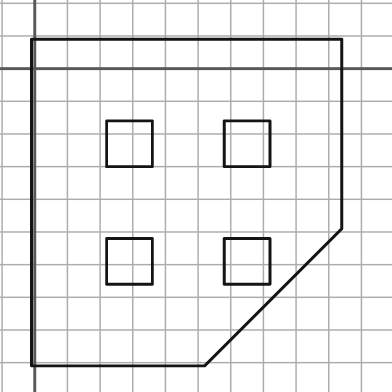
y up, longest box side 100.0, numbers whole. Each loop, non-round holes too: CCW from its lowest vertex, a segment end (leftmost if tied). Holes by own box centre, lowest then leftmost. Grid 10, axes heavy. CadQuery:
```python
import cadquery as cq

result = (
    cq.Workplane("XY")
    .moveTo(-1.0, -91.0)
    .lineTo(52.0, -91.0)
    .lineTo(94.0, -49.0)
    .lineTo(94.0, 9.0)
    .lineTo(-1.0, 9.0)
    .close()
    .moveTo(22.0, -66.0)
    .lineTo(36.0, -66.0)
    .lineTo(36.0, -52.0)
    .lineTo(22.0, -52.0)
    .close()
    .moveTo(58.0, -66.0)
    .lineTo(72.0, -66.0)
    .lineTo(72.0, -52.0)
    .lineTo(58.0, -52.0)
    .close()
    .moveTo(22.0, -30.0)
    .lineTo(36.0, -30.0)
    .lineTo(36.0, -16.0)
    .lineTo(22.0, -16.0)
    .close()
    .moveTo(58.0, -30.0)
    .lineTo(72.0, -30.0)
    .lineTo(72.0, -16.0)
    .lineTo(58.0, -16.0)
    .close()
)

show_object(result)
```